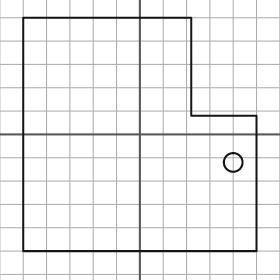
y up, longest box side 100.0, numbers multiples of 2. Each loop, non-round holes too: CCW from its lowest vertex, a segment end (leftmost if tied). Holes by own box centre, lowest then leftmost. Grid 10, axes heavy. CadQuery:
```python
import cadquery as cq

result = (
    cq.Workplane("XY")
    .moveTo(-50.0, -50.0)
    .lineTo(50.0, -50.0)
    .lineTo(50.0, 8.0)
    .lineTo(22.0, 8.0)
    .lineTo(22.0, 50.0)
    .lineTo(-50.0, 50.0)
    .close()
    .moveTo(40.0, -12.0)
    .circle(4.0)
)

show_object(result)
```